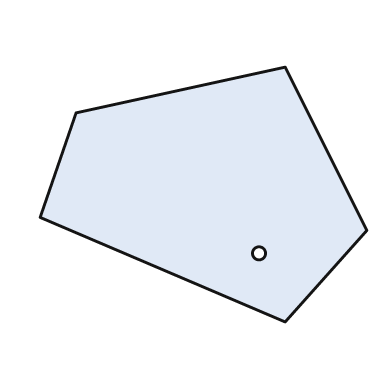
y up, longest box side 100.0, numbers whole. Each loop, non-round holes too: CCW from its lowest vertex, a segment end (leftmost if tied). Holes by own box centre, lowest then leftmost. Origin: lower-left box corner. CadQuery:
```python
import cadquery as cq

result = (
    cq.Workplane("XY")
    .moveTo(75.0, 0.0)
    .lineTo(100.0, 28.0)
    .lineTo(75.0, 78.0)
    .lineTo(11.0, 64.0)
    .lineTo(0.0, 32.0)
    .close()
    .moveTo(67.0, 21.0)
    .circle(2.0)
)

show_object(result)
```